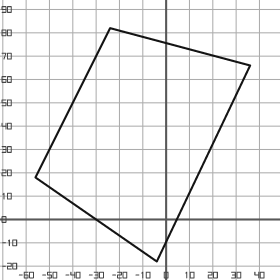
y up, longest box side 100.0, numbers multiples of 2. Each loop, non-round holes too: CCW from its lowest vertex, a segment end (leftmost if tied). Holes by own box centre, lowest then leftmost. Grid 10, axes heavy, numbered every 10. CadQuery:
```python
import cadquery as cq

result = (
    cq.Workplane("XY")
    .moveTo(-4.0, -18.0)
    .lineTo(36.0, 66.0)
    .lineTo(-24.0, 82.0)
    .lineTo(-56.0, 18.0)
    .close()
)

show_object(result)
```